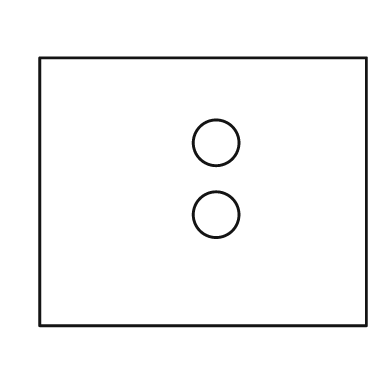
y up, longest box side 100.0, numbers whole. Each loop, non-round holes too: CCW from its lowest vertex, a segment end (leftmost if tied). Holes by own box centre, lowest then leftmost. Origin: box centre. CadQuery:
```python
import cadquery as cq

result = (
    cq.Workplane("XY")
    .moveTo(-50.0, -41.0)
    .lineTo(50.0, -41.0)
    .lineTo(50.0, 41.0)
    .lineTo(-50.0, 41.0)
    .close()
    .moveTo(4.0, -7.0)
    .circle(7.0)
    .moveTo(4.0, 15.0)
    .circle(7.0)
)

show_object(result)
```